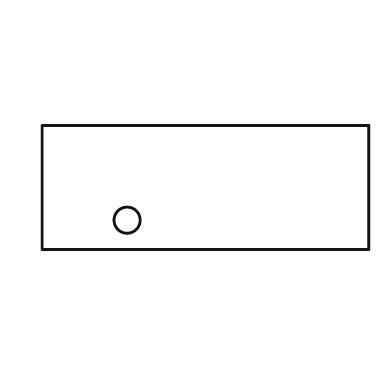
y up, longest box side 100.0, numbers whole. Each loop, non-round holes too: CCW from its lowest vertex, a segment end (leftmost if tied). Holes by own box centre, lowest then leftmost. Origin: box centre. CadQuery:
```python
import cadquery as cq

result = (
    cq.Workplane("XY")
    .moveTo(-50.0, -19.0)
    .lineTo(50.0, -19.0)
    .lineTo(50.0, 19.0)
    .lineTo(-50.0, 19.0)
    .close()
    .moveTo(-24.0, -10.0)
    .circle(4.0)
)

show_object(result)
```